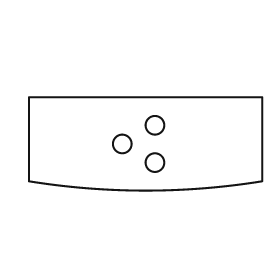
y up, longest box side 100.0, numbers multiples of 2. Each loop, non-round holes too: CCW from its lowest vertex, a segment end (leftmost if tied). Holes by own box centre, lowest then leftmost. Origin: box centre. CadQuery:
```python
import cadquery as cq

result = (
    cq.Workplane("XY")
    .moveTo(-50.0, -16.0)
    .threePointArc((0.0, -20.0), (50.0, -16.0))
    .lineTo(50.0, 20.0)
    .lineTo(-50.0, 20.0)
    .close()
    .moveTo(4.0, -8.0)
    .circle(4.0)
    .moveTo(-10.0, 0.0)
    .circle(4.0)
    .moveTo(4.0, 8.0)
    .circle(4.0)
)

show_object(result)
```